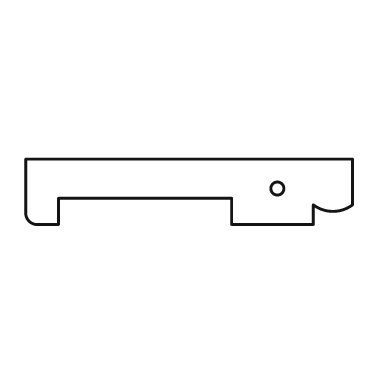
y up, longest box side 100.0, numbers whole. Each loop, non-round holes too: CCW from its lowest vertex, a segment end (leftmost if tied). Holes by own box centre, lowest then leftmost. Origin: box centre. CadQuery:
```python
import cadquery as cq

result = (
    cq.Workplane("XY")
    .moveTo(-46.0, -10.0)
    .lineTo(-40.0, -10.0)
    .lineTo(-40.0, -2.0)
    .lineTo(13.0, -2.0)
    .lineTo(13.0, -10.0)
    .lineTo(38.0, -10.0)
    .lineTo(38.0, -4.0)
    .threePointArc((44.0, -6.0), (50.0, -4.0))
    .lineTo(50.0, 10.0)
    .lineTo(-50.0, 10.0)
    .lineTo(-50.0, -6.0)
    .threePointArc((-49.0, -9.0), (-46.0, -10.0))
    .close()
    .moveTo(27.0, 1.0)
    .circle(2.0)
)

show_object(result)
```